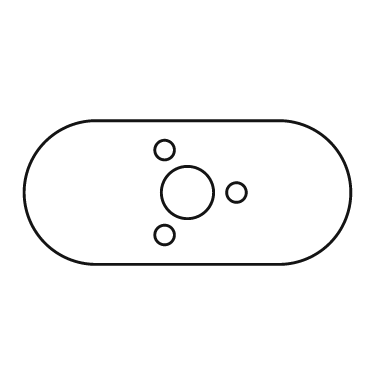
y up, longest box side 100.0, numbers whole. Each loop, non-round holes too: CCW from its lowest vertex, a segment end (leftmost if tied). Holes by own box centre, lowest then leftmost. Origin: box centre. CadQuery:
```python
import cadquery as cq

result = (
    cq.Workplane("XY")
    .moveTo(-28.0, -22.0)
    .lineTo(28.0, -22.0)
    .threePointArc((50.0, 0.0), (28.0, 22.0))
    .lineTo(-28.0, 22.0)
    .threePointArc((-50.0, 0.0), (-28.0, -22.0))
    .close()
    .moveTo(-7.0, -13.0)
    .circle(3.0)
    .moveTo(0.0, 0.0)
    .circle(8.0)
    .moveTo(15.0, 0.0)
    .circle(3.0)
    .moveTo(-7.0, 13.0)
    .circle(3.0)
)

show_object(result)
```